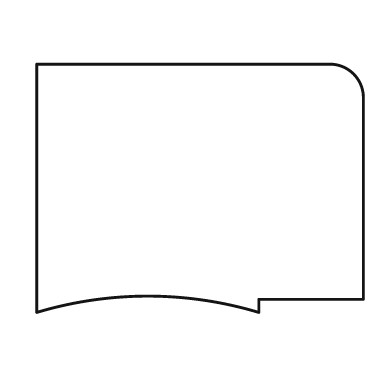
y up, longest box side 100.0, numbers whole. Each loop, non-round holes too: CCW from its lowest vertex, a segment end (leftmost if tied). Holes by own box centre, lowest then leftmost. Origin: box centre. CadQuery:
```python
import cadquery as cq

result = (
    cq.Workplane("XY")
    .moveTo(-50.0, -38.0)
    .threePointArc((-16.0, -33.0), (18.0, -38.0))
    .lineTo(18.0, -34.0)
    .lineTo(50.0, -34.0)
    .lineTo(50.0, 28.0)
    .threePointArc((47.0, 35.0), (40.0, 38.0))
    .lineTo(-50.0, 38.0)
    .close()
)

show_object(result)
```